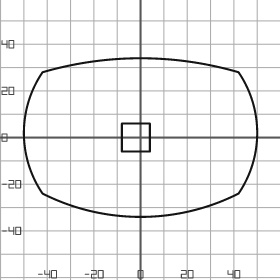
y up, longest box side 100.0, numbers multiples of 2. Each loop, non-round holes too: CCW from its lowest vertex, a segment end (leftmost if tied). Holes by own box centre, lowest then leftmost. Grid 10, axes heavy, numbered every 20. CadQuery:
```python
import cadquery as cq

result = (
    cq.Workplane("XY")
    .moveTo(-42.0, -24.0)
    .threePointArc((0.0, -34.0), (42.0, -24.0))
    .threePointArc((50.0, 2.0), (42.0, 28.0))
    .threePointArc((0.0, 34.0), (-42.0, 28.0))
    .threePointArc((-50.0, 2.0), (-42.0, -24.0))
    .close()
    .moveTo(-8.0, -6.0)
    .lineTo(4.0, -6.0)
    .lineTo(4.0, 6.0)
    .lineTo(-8.0, 6.0)
    .close()
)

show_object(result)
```